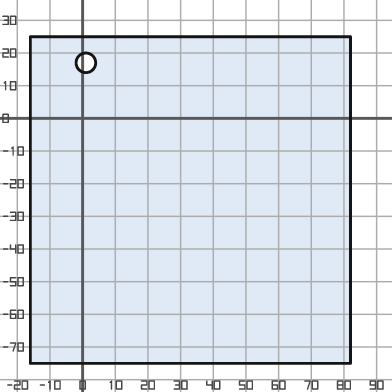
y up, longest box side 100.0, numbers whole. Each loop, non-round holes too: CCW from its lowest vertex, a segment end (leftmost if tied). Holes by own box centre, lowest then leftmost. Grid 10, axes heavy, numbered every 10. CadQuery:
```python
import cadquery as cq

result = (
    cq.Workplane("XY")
    .moveTo(-16.0, -75.0)
    .lineTo(82.0, -75.0)
    .lineTo(82.0, 25.0)
    .lineTo(-16.0, 25.0)
    .close()
    .moveTo(1.0, 17.0)
    .circle(3.0)
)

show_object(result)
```